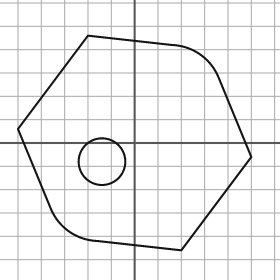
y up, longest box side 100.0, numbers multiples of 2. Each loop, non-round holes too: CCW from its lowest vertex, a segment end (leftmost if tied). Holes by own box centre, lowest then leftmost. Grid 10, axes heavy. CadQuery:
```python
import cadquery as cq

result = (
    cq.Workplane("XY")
    .moveTo(20.0, -46.0)
    .lineTo(50.0, -6.0)
    .lineTo(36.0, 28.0)
    .threePointArc((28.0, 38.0), (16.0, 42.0))
    .lineTo(-20.0, 46.0)
    .lineTo(-50.0, 6.0)
    .lineTo(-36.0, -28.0)
    .threePointArc((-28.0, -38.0), (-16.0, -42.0))
    .close()
    .moveTo(-14.0, -8.0)
    .circle(10.0)
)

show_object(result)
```